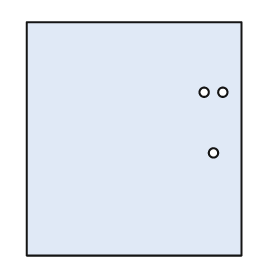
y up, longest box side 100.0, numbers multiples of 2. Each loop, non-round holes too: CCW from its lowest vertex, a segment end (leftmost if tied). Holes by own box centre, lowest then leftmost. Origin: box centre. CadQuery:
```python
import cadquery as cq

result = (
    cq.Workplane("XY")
    .moveTo(-46.0, -50.0)
    .lineTo(46.0, -50.0)
    .lineTo(46.0, 50.0)
    .lineTo(-46.0, 50.0)
    .close()
    .moveTo(34.0, -6.0)
    .circle(2.0)
    .moveTo(30.0, 20.0)
    .circle(2.0)
    .moveTo(38.0, 20.0)
    .circle(2.0)
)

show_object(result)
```